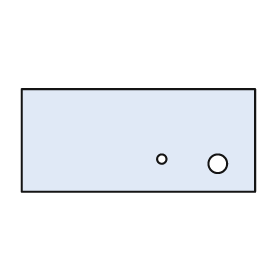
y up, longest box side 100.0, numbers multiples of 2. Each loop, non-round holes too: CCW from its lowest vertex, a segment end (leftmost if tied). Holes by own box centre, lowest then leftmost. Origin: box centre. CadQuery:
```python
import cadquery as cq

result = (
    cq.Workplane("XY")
    .moveTo(-50.0, -22.0)
    .lineTo(50.0, -22.0)
    .lineTo(50.0, 22.0)
    .lineTo(-50.0, 22.0)
    .close()
    .moveTo(34.0, -10.0)
    .circle(4.0)
    .moveTo(10.0, -8.0)
    .circle(2.0)
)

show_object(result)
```